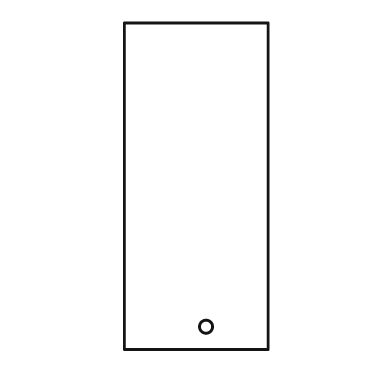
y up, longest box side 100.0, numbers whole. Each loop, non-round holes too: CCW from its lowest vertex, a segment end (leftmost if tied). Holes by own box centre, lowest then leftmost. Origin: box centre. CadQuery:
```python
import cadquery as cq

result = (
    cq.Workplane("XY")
    .moveTo(-22.0, -50.0)
    .lineTo(22.0, -50.0)
    .lineTo(22.0, 50.0)
    .lineTo(-22.0, 50.0)
    .close()
    .moveTo(3.0, -43.0)
    .circle(2.0)
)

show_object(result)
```